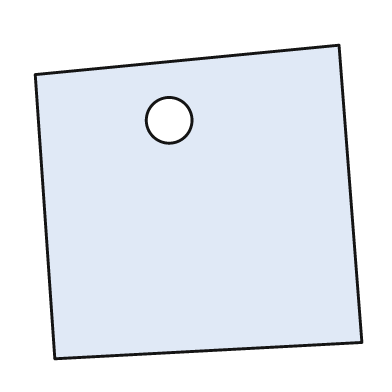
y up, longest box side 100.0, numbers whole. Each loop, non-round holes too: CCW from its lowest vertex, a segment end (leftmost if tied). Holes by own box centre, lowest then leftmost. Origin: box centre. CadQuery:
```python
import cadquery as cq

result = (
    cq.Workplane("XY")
    .moveTo(-44.0, -48.0)
    .lineTo(50.0, -43.0)
    .lineTo(43.0, 48.0)
    .lineTo(-50.0, 39.0)
    .close()
    .moveTo(-9.0, 25.0)
    .circle(7.0)
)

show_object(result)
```